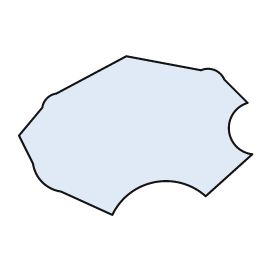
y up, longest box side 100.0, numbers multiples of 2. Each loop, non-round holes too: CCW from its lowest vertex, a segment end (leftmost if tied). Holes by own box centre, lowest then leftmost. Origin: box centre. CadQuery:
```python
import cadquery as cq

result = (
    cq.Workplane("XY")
    .moveTo(-10.0, -34.0)
    .threePointArc((8.0, -20.0), (30.0, -26.0))
    .lineTo(50.0, -8.0)
    .threePointArc((40.0, 2.0), (48.0, 14.0))
    .lineTo(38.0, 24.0)
    .threePointArc((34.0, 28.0), (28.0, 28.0))
    .lineTo(-4.0, 34.0)
    .lineTo(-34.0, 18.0)
    .threePointArc((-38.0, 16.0), (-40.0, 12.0))
    .lineTo(-50.0, 0.0)
    .lineTo(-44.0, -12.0)
    .threePointArc((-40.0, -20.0), (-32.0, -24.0))
    .close()
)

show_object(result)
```